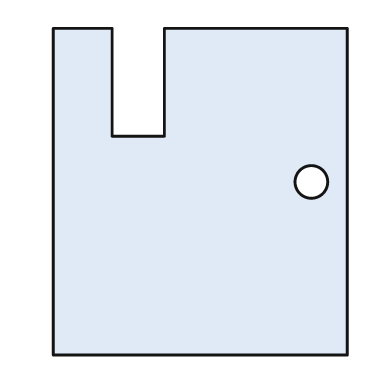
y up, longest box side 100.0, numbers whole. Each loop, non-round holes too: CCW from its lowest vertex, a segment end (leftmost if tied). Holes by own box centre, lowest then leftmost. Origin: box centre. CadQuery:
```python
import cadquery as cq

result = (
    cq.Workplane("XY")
    .moveTo(-45.0, -50.0)
    .lineTo(45.0, -50.0)
    .lineTo(45.0, 50.0)
    .lineTo(-11.0, 50.0)
    .lineTo(-11.0, 17.0)
    .lineTo(-27.0, 17.0)
    .lineTo(-27.0, 50.0)
    .lineTo(-45.0, 50.0)
    .close()
    .moveTo(34.0, 3.0)
    .circle(5.0)
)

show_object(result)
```